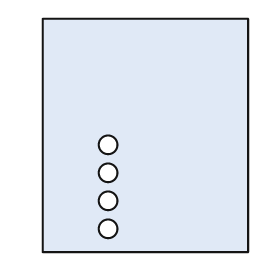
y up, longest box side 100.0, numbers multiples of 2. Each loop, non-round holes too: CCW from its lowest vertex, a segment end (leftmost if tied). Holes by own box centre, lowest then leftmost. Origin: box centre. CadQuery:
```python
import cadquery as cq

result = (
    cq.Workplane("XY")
    .moveTo(-44.0, -50.0)
    .lineTo(44.0, -50.0)
    .lineTo(44.0, 50.0)
    .lineTo(-44.0, 50.0)
    .close()
    .moveTo(-16.0, -40.0)
    .circle(4.0)
    .moveTo(-16.0, -28.0)
    .circle(4.0)
    .moveTo(-16.0, -16.0)
    .circle(4.0)
    .moveTo(-16.0, -4.0)
    .circle(4.0)
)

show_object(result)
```